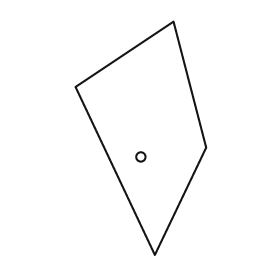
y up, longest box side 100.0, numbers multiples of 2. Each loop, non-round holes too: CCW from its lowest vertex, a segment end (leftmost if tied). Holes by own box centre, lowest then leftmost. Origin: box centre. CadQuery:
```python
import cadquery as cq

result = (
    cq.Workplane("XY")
    .moveTo(6.0, -50.0)
    .lineTo(28.0, -4.0)
    .lineTo(14.0, 50.0)
    .lineTo(-28.0, 22.0)
    .close()
    .moveTo(0.0, -8.0)
    .circle(2.0)
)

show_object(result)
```